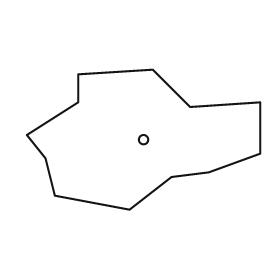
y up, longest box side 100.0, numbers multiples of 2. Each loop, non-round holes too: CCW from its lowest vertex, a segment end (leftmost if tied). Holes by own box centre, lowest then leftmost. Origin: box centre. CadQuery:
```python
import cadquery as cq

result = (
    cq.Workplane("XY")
    .moveTo(-6.0, -30.0)
    .lineTo(12.0, -16.0)
    .lineTo(28.0, -14.0)
    .lineTo(50.0, -6.0)
    .lineTo(50.0, 16.0)
    .lineTo(20.0, 14.0)
    .lineTo(4.0, 30.0)
    .lineTo(-28.0, 28.0)
    .lineTo(-28.0, 16.0)
    .lineTo(-50.0, 2.0)
    .lineTo(-42.0, -8.0)
    .lineTo(-38.0, -24.0)
    .close()
    .moveTo(0.0, 0.0)
    .circle(2.0)
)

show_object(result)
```